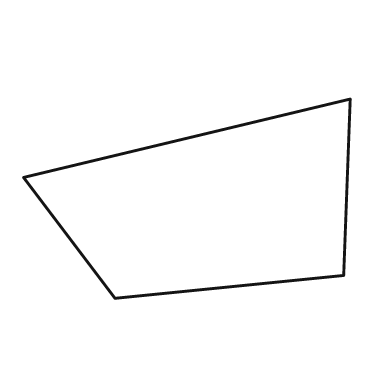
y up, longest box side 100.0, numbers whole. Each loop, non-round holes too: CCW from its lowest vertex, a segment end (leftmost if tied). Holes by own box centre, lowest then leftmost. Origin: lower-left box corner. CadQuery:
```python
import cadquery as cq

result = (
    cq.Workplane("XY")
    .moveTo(28.0, 0.0)
    .lineTo(98.0, 7.0)
    .lineTo(100.0, 61.0)
    .lineTo(0.0, 37.0)
    .close()
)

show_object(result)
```